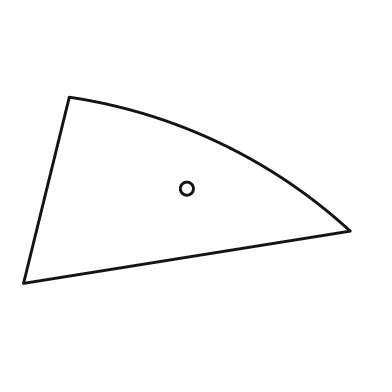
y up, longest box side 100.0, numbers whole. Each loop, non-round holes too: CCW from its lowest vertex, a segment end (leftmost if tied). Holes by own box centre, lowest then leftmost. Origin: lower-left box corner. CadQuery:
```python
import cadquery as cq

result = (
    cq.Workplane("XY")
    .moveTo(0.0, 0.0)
    .lineTo(100.0, 16.0)
    .threePointArc((60.0, 43.0), (14.0, 57.0))
    .close()
    .moveTo(50.0, 29.0)
    .circle(2.0)
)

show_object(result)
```